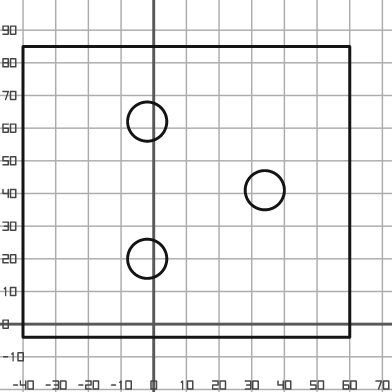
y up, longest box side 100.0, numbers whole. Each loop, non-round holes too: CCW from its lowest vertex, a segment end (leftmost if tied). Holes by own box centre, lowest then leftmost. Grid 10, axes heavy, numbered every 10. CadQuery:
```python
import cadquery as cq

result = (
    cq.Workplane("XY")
    .moveTo(-40.0, -4.0)
    .lineTo(60.0, -4.0)
    .lineTo(60.0, 85.0)
    .lineTo(-40.0, 85.0)
    .close()
    .moveTo(-2.0, 20.0)
    .circle(6.0)
    .moveTo(34.0, 41.0)
    .circle(6.0)
    .moveTo(-2.0, 62.0)
    .circle(6.0)
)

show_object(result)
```